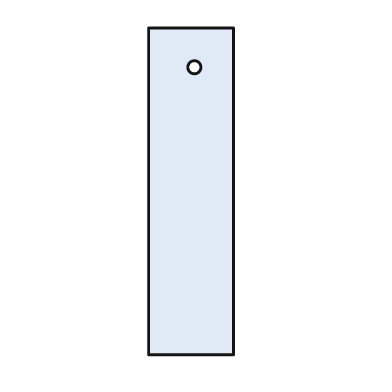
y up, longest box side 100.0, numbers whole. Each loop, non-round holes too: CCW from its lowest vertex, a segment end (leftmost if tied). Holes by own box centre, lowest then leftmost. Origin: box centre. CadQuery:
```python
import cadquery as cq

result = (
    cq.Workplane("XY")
    .moveTo(-13.0, -50.0)
    .lineTo(13.0, -50.0)
    .lineTo(13.0, 50.0)
    .lineTo(-13.0, 50.0)
    .close()
    .moveTo(1.0, 38.0)
    .circle(2.0)
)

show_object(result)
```